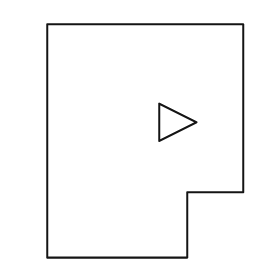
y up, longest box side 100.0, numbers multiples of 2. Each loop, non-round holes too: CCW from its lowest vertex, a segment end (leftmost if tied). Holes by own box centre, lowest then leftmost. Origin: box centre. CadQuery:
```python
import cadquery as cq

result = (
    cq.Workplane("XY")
    .moveTo(-42.0, -50.0)
    .lineTo(18.0, -50.0)
    .lineTo(18.0, -22.0)
    .lineTo(42.0, -22.0)
    .lineTo(42.0, 50.0)
    .lineTo(-42.0, 50.0)
    .close()
    .moveTo(6.0, 0.0)
    .lineTo(22.0, 8.0)
    .lineTo(6.0, 16.0)
    .close()
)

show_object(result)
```